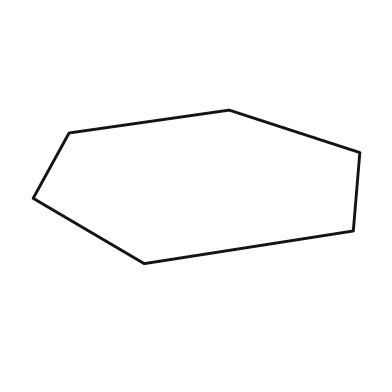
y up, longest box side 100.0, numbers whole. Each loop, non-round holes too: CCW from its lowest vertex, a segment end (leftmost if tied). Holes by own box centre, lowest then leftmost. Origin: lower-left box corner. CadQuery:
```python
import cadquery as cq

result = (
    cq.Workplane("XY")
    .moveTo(34.0, 0.0)
    .lineTo(98.0, 10.0)
    .lineTo(100.0, 34.0)
    .lineTo(60.0, 47.0)
    .lineTo(11.0, 40.0)
    .lineTo(0.0, 20.0)
    .close()
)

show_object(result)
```